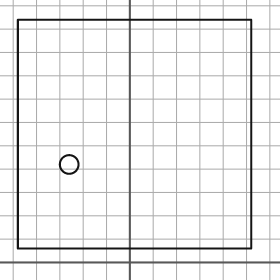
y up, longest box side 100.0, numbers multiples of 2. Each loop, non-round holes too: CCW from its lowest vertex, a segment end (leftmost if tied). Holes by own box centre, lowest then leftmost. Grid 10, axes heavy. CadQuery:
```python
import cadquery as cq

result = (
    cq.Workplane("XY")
    .moveTo(-48.0, 6.0)
    .lineTo(52.0, 6.0)
    .lineTo(52.0, 104.0)
    .lineTo(-48.0, 104.0)
    .close()
    .moveTo(-26.0, 42.0)
    .circle(4.0)
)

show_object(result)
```